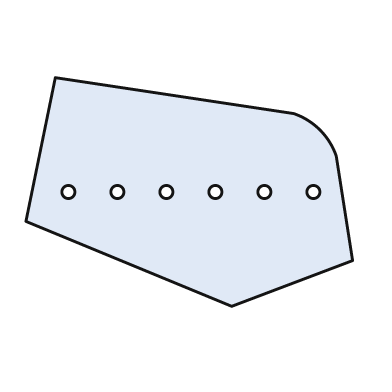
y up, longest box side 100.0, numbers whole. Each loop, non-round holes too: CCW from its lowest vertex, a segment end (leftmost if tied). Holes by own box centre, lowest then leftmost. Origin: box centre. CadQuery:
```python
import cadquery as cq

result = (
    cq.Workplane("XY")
    .moveTo(13.0, -35.0)
    .lineTo(50.0, -21.0)
    .lineTo(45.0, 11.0)
    .threePointArc((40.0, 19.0), (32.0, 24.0))
    .lineTo(-41.0, 35.0)
    .lineTo(-50.0, -9.0)
    .close()
    .moveTo(-37.0, 0.0)
    .circle(2.0)
    .moveTo(-22.0, 0.0)
    .circle(2.0)
    .moveTo(-7.0, 0.0)
    .circle(2.0)
    .moveTo(8.0, 0.0)
    .circle(2.0)
    .moveTo(23.0, 0.0)
    .circle(2.0)
    .moveTo(38.0, 0.0)
    .circle(2.0)
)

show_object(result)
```